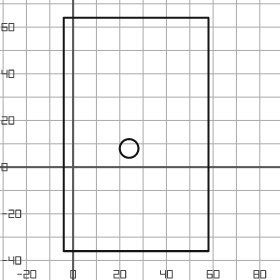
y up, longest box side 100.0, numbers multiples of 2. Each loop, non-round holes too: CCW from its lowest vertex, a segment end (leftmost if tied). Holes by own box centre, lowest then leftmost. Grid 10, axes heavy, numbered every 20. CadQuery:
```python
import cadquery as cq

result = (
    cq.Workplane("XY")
    .moveTo(-4.0, -36.0)
    .lineTo(58.0, -36.0)
    .lineTo(58.0, 64.0)
    .lineTo(-4.0, 64.0)
    .close()
    .moveTo(24.0, 8.0)
    .circle(4.0)
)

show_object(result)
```